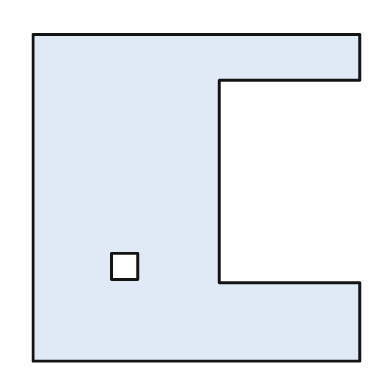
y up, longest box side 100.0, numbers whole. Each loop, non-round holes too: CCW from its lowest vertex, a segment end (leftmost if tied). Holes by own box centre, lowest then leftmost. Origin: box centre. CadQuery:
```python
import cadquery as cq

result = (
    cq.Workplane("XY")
    .moveTo(-50.0, -50.0)
    .lineTo(50.0, -50.0)
    .lineTo(50.0, -26.0)
    .lineTo(7.0, -26.0)
    .lineTo(7.0, 36.0)
    .lineTo(50.0, 36.0)
    .lineTo(50.0, 50.0)
    .lineTo(-50.0, 50.0)
    .close()
    .moveTo(-26.0, -25.0)
    .lineTo(-18.0, -25.0)
    .lineTo(-18.0, -17.0)
    .lineTo(-26.0, -17.0)
    .close()
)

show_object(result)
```